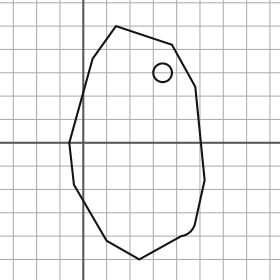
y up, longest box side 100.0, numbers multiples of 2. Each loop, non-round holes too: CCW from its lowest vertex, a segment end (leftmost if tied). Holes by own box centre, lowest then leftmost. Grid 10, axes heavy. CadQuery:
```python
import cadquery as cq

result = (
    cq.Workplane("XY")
    .moveTo(24.0, -50.0)
    .lineTo(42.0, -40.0)
    .threePointArc((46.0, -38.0), (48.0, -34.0))
    .lineTo(52.0, -16.0)
    .lineTo(48.0, 24.0)
    .lineTo(38.0, 42.0)
    .lineTo(14.0, 50.0)
    .lineTo(4.0, 36.0)
    .lineTo(-6.0, 0.0)
    .lineTo(-4.0, -18.0)
    .lineTo(10.0, -42.0)
    .close()
    .moveTo(34.0, 30.0)
    .circle(4.0)
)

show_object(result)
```